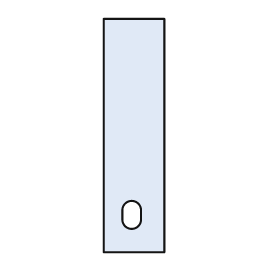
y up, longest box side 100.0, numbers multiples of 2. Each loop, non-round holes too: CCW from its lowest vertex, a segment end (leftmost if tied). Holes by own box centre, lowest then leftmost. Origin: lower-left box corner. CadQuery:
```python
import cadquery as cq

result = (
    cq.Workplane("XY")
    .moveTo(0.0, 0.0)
    .lineTo(26.0, 0.0)
    .lineTo(26.0, 100.0)
    .lineTo(0.0, 100.0)
    .close()
    .moveTo(8.0, 14.0)
    .threePointArc((12.0, 10.0), (16.0, 14.0))
    .lineTo(16.0, 18.0)
    .threePointArc((12.0, 22.0), (8.0, 18.0))
    .close()
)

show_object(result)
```